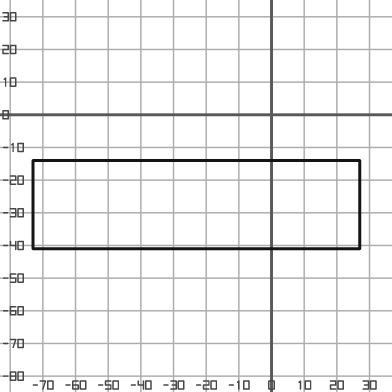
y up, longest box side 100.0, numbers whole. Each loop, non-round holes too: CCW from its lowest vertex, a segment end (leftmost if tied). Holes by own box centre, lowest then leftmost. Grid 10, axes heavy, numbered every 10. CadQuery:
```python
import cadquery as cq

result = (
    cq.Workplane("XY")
    .moveTo(-73.0, -41.0)
    .lineTo(27.0, -41.0)
    .lineTo(27.0, -14.0)
    .lineTo(-73.0, -14.0)
    .close()
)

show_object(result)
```